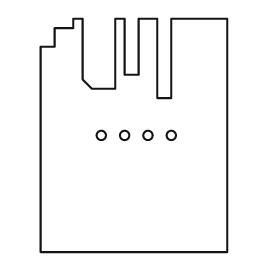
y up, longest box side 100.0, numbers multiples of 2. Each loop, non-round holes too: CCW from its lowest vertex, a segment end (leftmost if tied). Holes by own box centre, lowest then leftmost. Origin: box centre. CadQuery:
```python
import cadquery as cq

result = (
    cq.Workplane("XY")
    .moveTo(-40.0, -50.0)
    .lineTo(40.0, -50.0)
    .lineTo(40.0, 50.0)
    .lineTo(16.0, 50.0)
    .lineTo(16.0, 16.0)
    .lineTo(10.0, 16.0)
    .lineTo(10.0, 50.0)
    .lineTo(2.0, 50.0)
    .lineTo(2.0, 26.0)
    .lineTo(-4.0, 26.0)
    .lineTo(-4.0, 50.0)
    .lineTo(-8.0, 50.0)
    .lineTo(-8.0, 20.0)
    .lineTo(-18.0, 20.0)
    .lineTo(-22.0, 24.0)
    .lineTo(-22.0, 50.0)
    .lineTo(-26.0, 50.0)
    .lineTo(-26.0, 46.0)
    .lineTo(-34.0, 46.0)
    .lineTo(-34.0, 38.0)
    .lineTo(-40.0, 38.0)
    .close()
    .moveTo(-14.0, 0.0)
    .circle(2.0)
    .moveTo(-4.0, 0.0)
    .circle(2.0)
    .moveTo(6.0, 0.0)
    .circle(2.0)
    .moveTo(16.0, 0.0)
    .circle(2.0)
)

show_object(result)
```